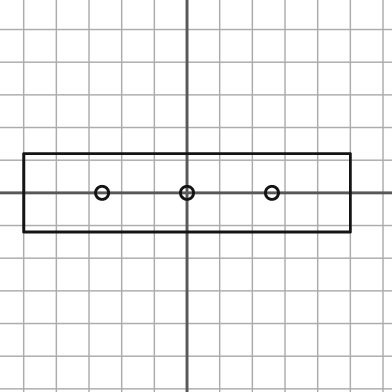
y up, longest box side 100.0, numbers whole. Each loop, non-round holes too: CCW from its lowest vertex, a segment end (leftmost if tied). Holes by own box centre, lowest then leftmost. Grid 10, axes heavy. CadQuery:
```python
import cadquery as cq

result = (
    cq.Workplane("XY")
    .moveTo(-50.0, -12.0)
    .lineTo(50.0, -12.0)
    .lineTo(50.0, 12.0)
    .lineTo(-50.0, 12.0)
    .close()
    .moveTo(-26.0, 0.0)
    .circle(2.0)
    .moveTo(0.0, 0.0)
    .circle(2.0)
    .moveTo(26.0, 0.0)
    .circle(2.0)
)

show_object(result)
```